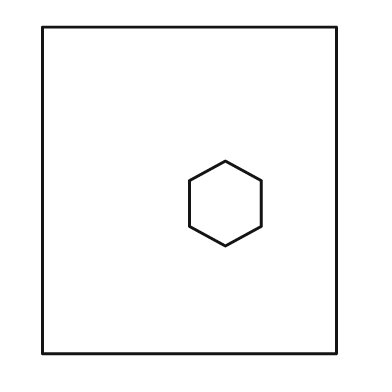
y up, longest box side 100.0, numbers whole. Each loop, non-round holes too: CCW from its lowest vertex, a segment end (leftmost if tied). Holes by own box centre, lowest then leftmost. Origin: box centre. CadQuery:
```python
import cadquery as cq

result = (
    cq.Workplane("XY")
    .moveTo(-45.0, -50.0)
    .lineTo(45.0, -50.0)
    .lineTo(45.0, 50.0)
    .lineTo(-45.0, 50.0)
    .close()
    .moveTo(11.0, -17.0)
    .lineTo(22.0, -11.0)
    .lineTo(22.0, 3.0)
    .lineTo(11.0, 9.0)
    .lineTo(0.0, 3.0)
    .lineTo(0.0, -11.0)
    .close()
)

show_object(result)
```